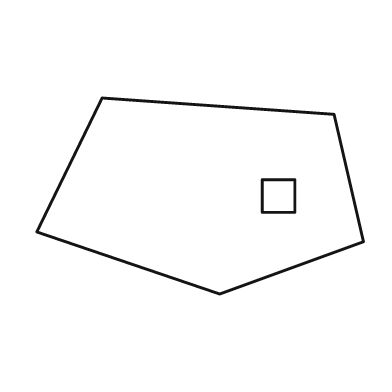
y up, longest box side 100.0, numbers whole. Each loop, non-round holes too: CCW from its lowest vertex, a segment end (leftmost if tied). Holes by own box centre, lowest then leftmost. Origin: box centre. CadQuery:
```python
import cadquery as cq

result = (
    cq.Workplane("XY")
    .moveTo(6.0, -30.0)
    .lineTo(50.0, -14.0)
    .lineTo(41.0, 25.0)
    .lineTo(-30.0, 30.0)
    .lineTo(-50.0, -11.0)
    .close()
    .moveTo(19.0, -5.0)
    .lineTo(29.0, -5.0)
    .lineTo(29.0, 5.0)
    .lineTo(19.0, 5.0)
    .close()
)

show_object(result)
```